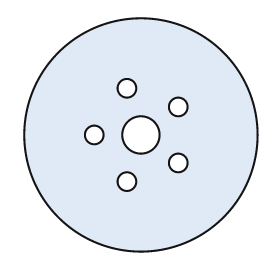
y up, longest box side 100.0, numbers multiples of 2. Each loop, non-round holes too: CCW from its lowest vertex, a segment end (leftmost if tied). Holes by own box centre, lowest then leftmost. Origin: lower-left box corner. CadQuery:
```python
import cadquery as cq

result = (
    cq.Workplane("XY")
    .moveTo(50.0, 50.0)
    .circle(50.0)
    .moveTo(44.0, 30.0)
    .circle(4.0)
    .moveTo(66.0, 38.0)
    .circle(4.0)
    .moveTo(30.0, 50.0)
    .circle(4.0)
    .moveTo(50.0, 50.0)
    .circle(8.0)
    .moveTo(66.0, 62.0)
    .circle(4.0)
    .moveTo(44.0, 70.0)
    .circle(4.0)
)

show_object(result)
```